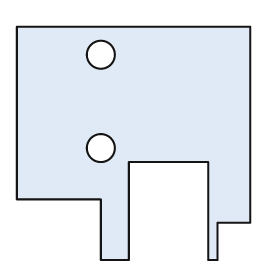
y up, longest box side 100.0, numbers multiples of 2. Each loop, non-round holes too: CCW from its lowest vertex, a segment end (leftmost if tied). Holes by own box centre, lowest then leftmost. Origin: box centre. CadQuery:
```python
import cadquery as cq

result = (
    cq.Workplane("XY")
    .moveTo(-14.0, -50.0)
    .lineTo(-2.0, -50.0)
    .lineTo(-2.0, -8.0)
    .lineTo(32.0, -8.0)
    .lineTo(32.0, -50.0)
    .lineTo(36.0, -50.0)
    .lineTo(36.0, -34.0)
    .lineTo(50.0, -34.0)
    .lineTo(50.0, 50.0)
    .lineTo(-50.0, 50.0)
    .lineTo(-50.0, -24.0)
    .lineTo(-14.0, -24.0)
    .close()
    .moveTo(-14.0, -2.0)
    .circle(6.0)
    .moveTo(-14.0, 38.0)
    .circle(6.0)
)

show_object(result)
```